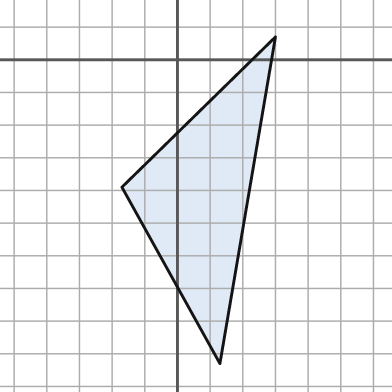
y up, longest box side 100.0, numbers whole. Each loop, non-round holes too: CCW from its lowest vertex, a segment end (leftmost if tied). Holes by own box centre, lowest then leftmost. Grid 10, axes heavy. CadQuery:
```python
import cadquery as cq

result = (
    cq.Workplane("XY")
    .moveTo(13.0, -93.0)
    .lineTo(30.0, 7.0)
    .lineTo(-17.0, -39.0)
    .close()
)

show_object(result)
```